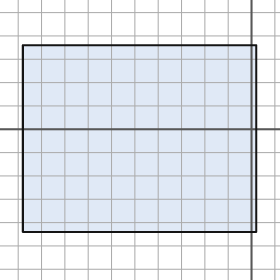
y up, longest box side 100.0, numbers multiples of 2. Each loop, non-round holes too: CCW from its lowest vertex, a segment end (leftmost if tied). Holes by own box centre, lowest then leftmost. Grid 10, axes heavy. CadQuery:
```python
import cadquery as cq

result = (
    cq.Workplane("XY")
    .moveTo(-98.0, -44.0)
    .lineTo(2.0, -44.0)
    .lineTo(2.0, 36.0)
    .lineTo(-98.0, 36.0)
    .close()
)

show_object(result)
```